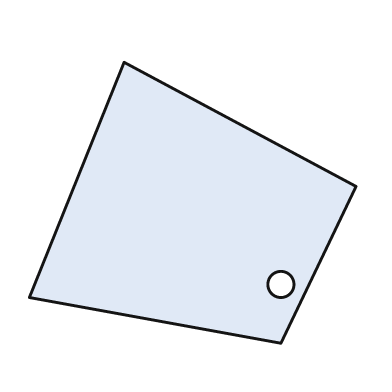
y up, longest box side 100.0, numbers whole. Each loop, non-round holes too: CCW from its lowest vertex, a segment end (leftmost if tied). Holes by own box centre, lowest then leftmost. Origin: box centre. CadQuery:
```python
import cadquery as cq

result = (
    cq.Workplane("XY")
    .moveTo(27.0, -43.0)
    .lineTo(50.0, 5.0)
    .lineTo(-21.0, 43.0)
    .lineTo(-50.0, -29.0)
    .close()
    .moveTo(27.0, -25.0)
    .circle(4.0)
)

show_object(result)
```